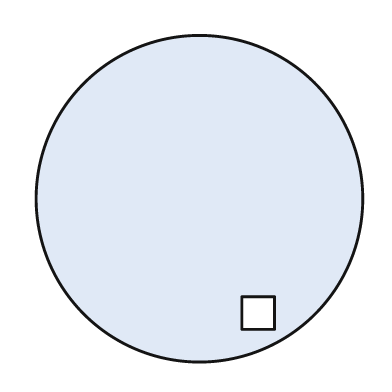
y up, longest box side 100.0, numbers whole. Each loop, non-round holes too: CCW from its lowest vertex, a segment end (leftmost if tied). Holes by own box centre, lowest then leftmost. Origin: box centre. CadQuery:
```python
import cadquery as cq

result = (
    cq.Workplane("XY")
    .moveTo(0.0, 0.0)
    .circle(50.0)
    .moveTo(13.0, -40.0)
    .lineTo(23.0, -40.0)
    .lineTo(23.0, -30.0)
    .lineTo(13.0, -30.0)
    .close()
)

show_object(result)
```